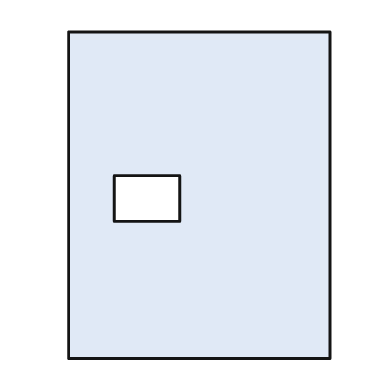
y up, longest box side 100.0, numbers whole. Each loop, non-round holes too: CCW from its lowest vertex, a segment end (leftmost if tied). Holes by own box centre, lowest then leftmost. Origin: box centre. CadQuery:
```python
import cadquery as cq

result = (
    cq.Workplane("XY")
    .moveTo(-40.0, -50.0)
    .lineTo(40.0, -50.0)
    .lineTo(40.0, 50.0)
    .lineTo(-40.0, 50.0)
    .close()
    .moveTo(-26.0, -8.0)
    .lineTo(-6.0, -8.0)
    .lineTo(-6.0, 6.0)
    .lineTo(-26.0, 6.0)
    .close()
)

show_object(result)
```